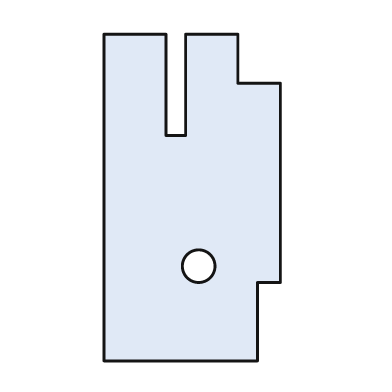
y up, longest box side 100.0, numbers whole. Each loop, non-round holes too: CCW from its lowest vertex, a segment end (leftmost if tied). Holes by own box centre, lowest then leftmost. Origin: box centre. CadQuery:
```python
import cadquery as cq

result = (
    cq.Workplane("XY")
    .moveTo(-27.0, -50.0)
    .lineTo(20.0, -50.0)
    .lineTo(20.0, -26.0)
    .lineTo(27.0, -26.0)
    .lineTo(27.0, 35.0)
    .lineTo(14.0, 35.0)
    .lineTo(14.0, 50.0)
    .lineTo(-2.0, 50.0)
    .lineTo(-2.0, 19.0)
    .lineTo(-8.0, 19.0)
    .lineTo(-8.0, 50.0)
    .lineTo(-27.0, 50.0)
    .close()
    .moveTo(2.0, -21.0)
    .circle(5.0)
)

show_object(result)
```